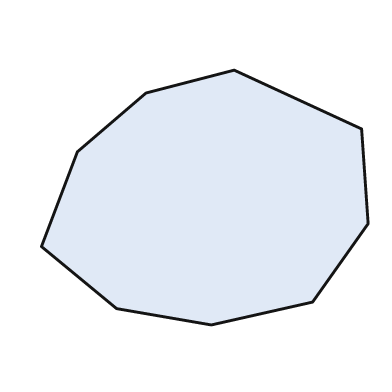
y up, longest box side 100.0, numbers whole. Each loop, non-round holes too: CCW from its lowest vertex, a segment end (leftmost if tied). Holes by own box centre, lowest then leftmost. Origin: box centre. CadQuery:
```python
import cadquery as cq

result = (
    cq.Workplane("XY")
    .moveTo(2.0, -39.0)
    .lineTo(33.0, -32.0)
    .lineTo(50.0, -8.0)
    .lineTo(48.0, 21.0)
    .lineTo(9.0, 39.0)
    .lineTo(-18.0, 32.0)
    .lineTo(-39.0, 14.0)
    .lineTo(-50.0, -15.0)
    .lineTo(-27.0, -34.0)
    .close()
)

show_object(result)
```